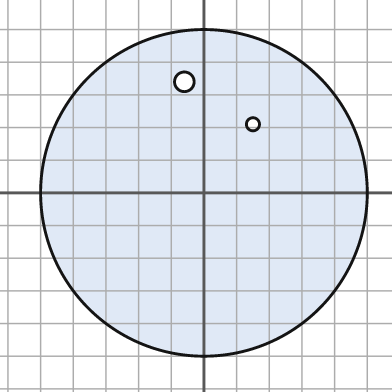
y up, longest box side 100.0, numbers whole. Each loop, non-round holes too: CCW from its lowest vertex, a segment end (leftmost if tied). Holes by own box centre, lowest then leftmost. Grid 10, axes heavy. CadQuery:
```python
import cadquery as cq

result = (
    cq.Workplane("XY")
    .moveTo(0.0, 0.0)
    .circle(50.0)
    .moveTo(15.0, 21.0)
    .circle(2.0)
    .moveTo(-6.0, 34.0)
    .circle(3.0)
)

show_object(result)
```